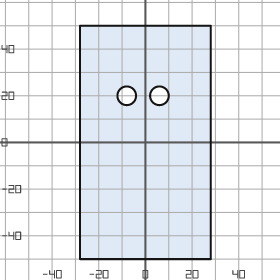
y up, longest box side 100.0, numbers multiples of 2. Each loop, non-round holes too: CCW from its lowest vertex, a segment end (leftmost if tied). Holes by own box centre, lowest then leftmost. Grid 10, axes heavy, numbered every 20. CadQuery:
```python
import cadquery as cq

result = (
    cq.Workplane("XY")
    .moveTo(-28.0, -50.0)
    .lineTo(28.0, -50.0)
    .lineTo(28.0, 50.0)
    .lineTo(-28.0, 50.0)
    .close()
    .moveTo(-8.0, 20.0)
    .circle(4.0)
    .moveTo(6.0, 20.0)
    .circle(4.0)
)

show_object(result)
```